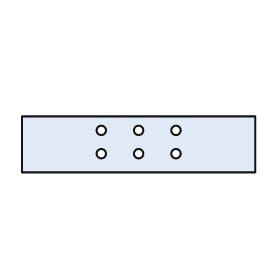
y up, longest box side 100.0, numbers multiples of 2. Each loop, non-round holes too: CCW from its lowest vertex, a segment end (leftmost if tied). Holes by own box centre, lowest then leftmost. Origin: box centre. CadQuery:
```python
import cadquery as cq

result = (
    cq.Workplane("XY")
    .moveTo(-50.0, -12.0)
    .lineTo(50.0, -12.0)
    .lineTo(50.0, 12.0)
    .lineTo(-50.0, 12.0)
    .close()
    .moveTo(-16.0, -4.0)
    .circle(2.0)
    .moveTo(0.0, -4.0)
    .circle(2.0)
    .moveTo(16.0, -4.0)
    .circle(2.0)
    .moveTo(-16.0, 6.0)
    .circle(2.0)
    .moveTo(0.0, 6.0)
    .circle(2.0)
    .moveTo(16.0, 6.0)
    .circle(2.0)
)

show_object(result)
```